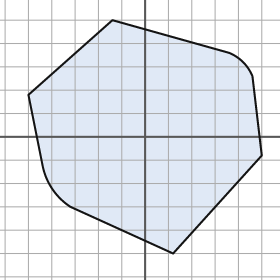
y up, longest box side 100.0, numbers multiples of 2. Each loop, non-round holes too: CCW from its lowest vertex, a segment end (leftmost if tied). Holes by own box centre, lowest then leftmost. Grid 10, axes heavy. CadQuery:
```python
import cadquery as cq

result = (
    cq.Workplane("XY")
    .moveTo(12.0, -50.0)
    .lineTo(50.0, -8.0)
    .lineTo(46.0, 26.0)
    .threePointArc((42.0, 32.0), (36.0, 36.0))
    .lineTo(-14.0, 50.0)
    .lineTo(-50.0, 18.0)
    .lineTo(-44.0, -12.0)
    .threePointArc((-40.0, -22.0), (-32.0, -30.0))
    .close()
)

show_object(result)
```